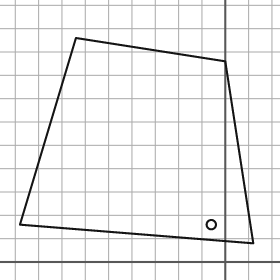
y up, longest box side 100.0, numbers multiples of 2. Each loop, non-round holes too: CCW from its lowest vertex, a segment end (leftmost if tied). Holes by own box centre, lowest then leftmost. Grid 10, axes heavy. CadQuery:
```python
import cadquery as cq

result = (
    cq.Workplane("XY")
    .moveTo(12.0, 8.0)
    .lineTo(0.0, 86.0)
    .lineTo(-64.0, 96.0)
    .lineTo(-88.0, 16.0)
    .close()
    .moveTo(-6.0, 16.0)
    .circle(2.0)
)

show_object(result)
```